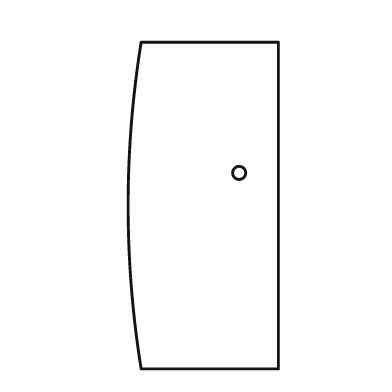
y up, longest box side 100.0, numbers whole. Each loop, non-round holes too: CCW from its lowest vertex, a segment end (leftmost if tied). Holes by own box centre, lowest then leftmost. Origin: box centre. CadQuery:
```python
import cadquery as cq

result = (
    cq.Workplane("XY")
    .moveTo(-19.0, -50.0)
    .lineTo(23.0, -50.0)
    .lineTo(23.0, 50.0)
    .lineTo(-19.0, 50.0)
    .threePointArc((-23.0, 0.0), (-19.0, -50.0))
    .close()
    .moveTo(11.0, 10.0)
    .circle(2.0)
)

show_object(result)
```